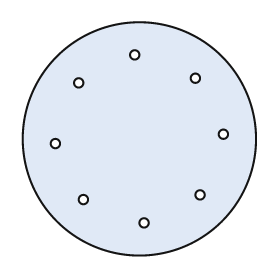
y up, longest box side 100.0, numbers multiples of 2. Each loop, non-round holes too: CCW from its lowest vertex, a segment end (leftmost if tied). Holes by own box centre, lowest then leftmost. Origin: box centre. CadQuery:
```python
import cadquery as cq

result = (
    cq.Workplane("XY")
    .moveTo(0.0, 0.0)
    .circle(50.0)
    .moveTo(2.0, -36.0)
    .circle(2.0)
    .moveTo(-24.0, -26.0)
    .circle(2.0)
    .moveTo(26.0, -24.0)
    .circle(2.0)
    .moveTo(-36.0, -2.0)
    .circle(2.0)
    .moveTo(36.0, 2.0)
    .circle(2.0)
    .moveTo(-26.0, 24.0)
    .circle(2.0)
    .moveTo(24.0, 26.0)
    .circle(2.0)
    .moveTo(-2.0, 36.0)
    .circle(2.0)
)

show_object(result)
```